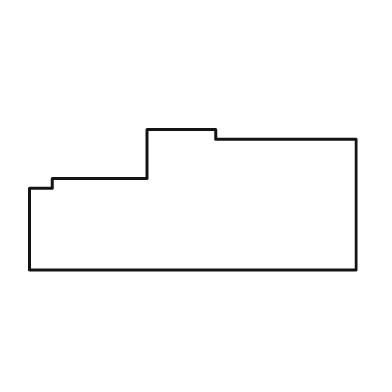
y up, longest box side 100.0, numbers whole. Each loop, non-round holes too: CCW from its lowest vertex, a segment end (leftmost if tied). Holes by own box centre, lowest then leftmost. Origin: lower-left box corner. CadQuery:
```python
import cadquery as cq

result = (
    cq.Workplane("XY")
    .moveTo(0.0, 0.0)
    .lineTo(100.0, 0.0)
    .lineTo(100.0, 40.0)
    .lineTo(57.0, 40.0)
    .lineTo(57.0, 43.0)
    .lineTo(36.0, 43.0)
    .lineTo(36.0, 28.0)
    .lineTo(7.0, 28.0)
    .lineTo(7.0, 25.0)
    .lineTo(0.0, 25.0)
    .close()
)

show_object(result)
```